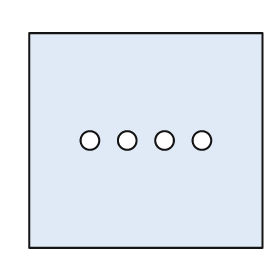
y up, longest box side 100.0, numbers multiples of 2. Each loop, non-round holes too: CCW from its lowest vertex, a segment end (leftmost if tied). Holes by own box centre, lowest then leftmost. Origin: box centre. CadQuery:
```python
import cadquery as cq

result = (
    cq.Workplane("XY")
    .moveTo(-50.0, -46.0)
    .lineTo(50.0, -46.0)
    .lineTo(50.0, 46.0)
    .lineTo(-50.0, 46.0)
    .close()
    .moveTo(-24.0, 0.0)
    .circle(4.0)
    .moveTo(-8.0, 0.0)
    .circle(4.0)
    .moveTo(8.0, 0.0)
    .circle(4.0)
    .moveTo(24.0, 0.0)
    .circle(4.0)
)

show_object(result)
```